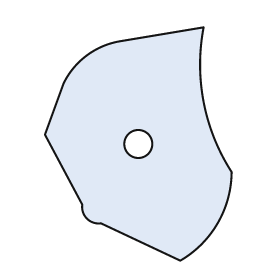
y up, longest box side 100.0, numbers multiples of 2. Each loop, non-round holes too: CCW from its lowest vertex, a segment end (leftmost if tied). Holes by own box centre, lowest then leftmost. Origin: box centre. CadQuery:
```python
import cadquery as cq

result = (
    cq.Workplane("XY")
    .moveTo(18.0, -50.0)
    .threePointArc((34.0, -34.0), (40.0, -12.0))
    .threePointArc((28.0, 18.0), (28.0, 50.0))
    .lineTo(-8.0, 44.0)
    .threePointArc((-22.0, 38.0), (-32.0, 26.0))
    .lineTo(-40.0, 4.0)
    .lineTo(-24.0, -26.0)
    .threePointArc((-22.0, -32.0), (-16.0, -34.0))
    .close()
    .moveTo(0.0, 0.0)
    .circle(6.0)
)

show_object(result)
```